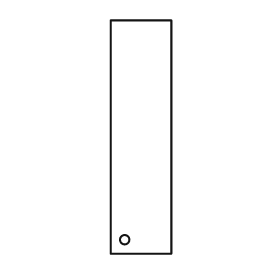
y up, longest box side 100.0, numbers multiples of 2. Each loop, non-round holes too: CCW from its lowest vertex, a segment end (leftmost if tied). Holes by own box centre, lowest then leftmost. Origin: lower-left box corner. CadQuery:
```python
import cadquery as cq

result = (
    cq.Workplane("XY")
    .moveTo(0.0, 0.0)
    .lineTo(26.0, 0.0)
    .lineTo(26.0, 100.0)
    .lineTo(0.0, 100.0)
    .close()
    .moveTo(6.0, 6.0)
    .circle(2.0)
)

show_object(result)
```